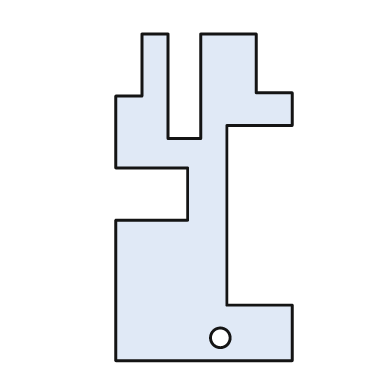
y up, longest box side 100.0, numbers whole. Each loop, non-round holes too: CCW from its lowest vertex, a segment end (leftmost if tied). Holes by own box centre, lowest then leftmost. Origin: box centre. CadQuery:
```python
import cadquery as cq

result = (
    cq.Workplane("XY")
    .moveTo(-27.0, -50.0)
    .lineTo(27.0, -50.0)
    .lineTo(27.0, -33.0)
    .lineTo(7.0, -33.0)
    .lineTo(7.0, 22.0)
    .lineTo(27.0, 22.0)
    .lineTo(27.0, 32.0)
    .lineTo(16.0, 32.0)
    .lineTo(16.0, 50.0)
    .lineTo(-1.0, 50.0)
    .lineTo(-1.0, 18.0)
    .lineTo(-11.0, 18.0)
    .lineTo(-11.0, 50.0)
    .lineTo(-19.0, 50.0)
    .lineTo(-19.0, 31.0)
    .lineTo(-27.0, 31.0)
    .lineTo(-27.0, 9.0)
    .lineTo(-5.0, 9.0)
    .lineTo(-5.0, -7.0)
    .lineTo(-27.0, -7.0)
    .close()
    .moveTo(5.0, -43.0)
    .circle(3.0)
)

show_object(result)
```